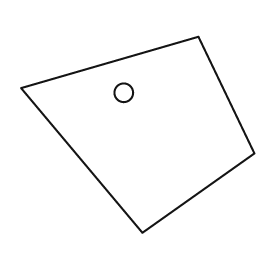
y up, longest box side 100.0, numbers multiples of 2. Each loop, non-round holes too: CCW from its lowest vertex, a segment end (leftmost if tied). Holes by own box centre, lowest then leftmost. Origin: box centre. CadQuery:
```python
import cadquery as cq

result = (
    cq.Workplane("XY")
    .moveTo(2.0, -42.0)
    .lineTo(50.0, -8.0)
    .lineTo(26.0, 42.0)
    .lineTo(-50.0, 20.0)
    .close()
    .moveTo(-6.0, 18.0)
    .circle(4.0)
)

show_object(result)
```